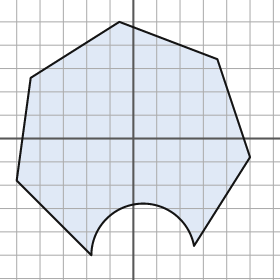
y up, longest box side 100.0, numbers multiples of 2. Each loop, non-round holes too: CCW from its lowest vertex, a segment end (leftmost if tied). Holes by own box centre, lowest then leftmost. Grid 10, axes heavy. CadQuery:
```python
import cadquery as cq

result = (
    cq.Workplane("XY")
    .moveTo(-18.0, -50.0)
    .threePointArc((2.0, -28.0), (26.0, -46.0))
    .lineTo(50.0, -8.0)
    .lineTo(36.0, 34.0)
    .lineTo(-6.0, 50.0)
    .lineTo(-44.0, 26.0)
    .lineTo(-50.0, -18.0)
    .close()
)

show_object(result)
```